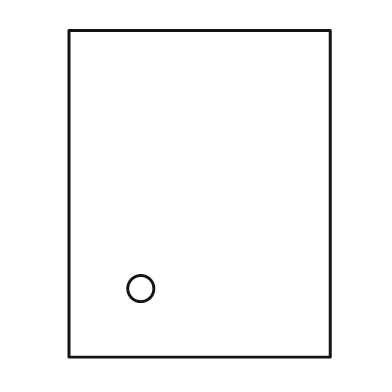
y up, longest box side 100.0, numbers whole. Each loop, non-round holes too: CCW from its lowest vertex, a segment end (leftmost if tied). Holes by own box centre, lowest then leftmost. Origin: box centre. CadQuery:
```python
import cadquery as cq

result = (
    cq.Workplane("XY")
    .moveTo(-40.0, -50.0)
    .lineTo(40.0, -50.0)
    .lineTo(40.0, 50.0)
    .lineTo(-40.0, 50.0)
    .close()
    .moveTo(-18.0, -29.0)
    .circle(4.0)
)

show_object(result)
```